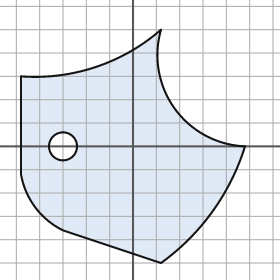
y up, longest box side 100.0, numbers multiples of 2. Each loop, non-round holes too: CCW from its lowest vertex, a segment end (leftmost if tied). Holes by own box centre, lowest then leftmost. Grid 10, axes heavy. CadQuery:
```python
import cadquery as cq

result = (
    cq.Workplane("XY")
    .moveTo(12.0, -50.0)
    .threePointArc((34.0, -28.0), (48.0, 0.0))
    .threePointArc((18.0, 16.0), (12.0, 50.0))
    .threePointArc((-16.0, 34.0), (-48.0, 30.0))
    .lineTo(-48.0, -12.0)
    .threePointArc((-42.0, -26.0), (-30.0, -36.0))
    .close()
    .moveTo(-30.0, 0.0)
    .circle(6.0)
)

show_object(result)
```